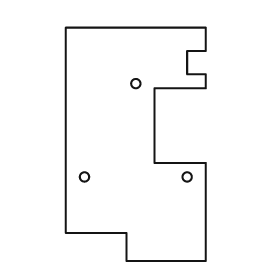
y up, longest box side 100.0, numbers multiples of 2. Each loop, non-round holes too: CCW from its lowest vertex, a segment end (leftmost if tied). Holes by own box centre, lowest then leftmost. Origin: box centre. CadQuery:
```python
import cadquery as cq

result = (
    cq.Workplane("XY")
    .moveTo(-4.0, -50.0)
    .lineTo(30.0, -50.0)
    .lineTo(30.0, -8.0)
    .lineTo(8.0, -8.0)
    .lineTo(8.0, 24.0)
    .lineTo(30.0, 24.0)
    .lineTo(30.0, 30.0)
    .lineTo(22.0, 30.0)
    .lineTo(22.0, 40.0)
    .lineTo(30.0, 40.0)
    .lineTo(30.0, 50.0)
    .lineTo(-30.0, 50.0)
    .lineTo(-30.0, -38.0)
    .lineTo(-4.0, -38.0)
    .close()
    .moveTo(-22.0, -14.0)
    .circle(2.0)
    .moveTo(22.0, -14.0)
    .circle(2.0)
    .moveTo(0.0, 26.0)
    .circle(2.0)
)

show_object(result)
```